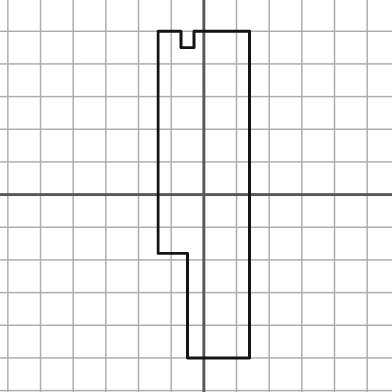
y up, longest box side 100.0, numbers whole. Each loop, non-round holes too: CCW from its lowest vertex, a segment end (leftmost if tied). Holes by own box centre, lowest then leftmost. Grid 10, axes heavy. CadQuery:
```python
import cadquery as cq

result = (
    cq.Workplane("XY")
    .moveTo(-5.0, -50.0)
    .lineTo(14.0, -50.0)
    .lineTo(14.0, 50.0)
    .lineTo(-3.0, 50.0)
    .lineTo(-3.0, 45.0)
    .lineTo(-7.0, 45.0)
    .lineTo(-7.0, 50.0)
    .lineTo(-14.0, 50.0)
    .lineTo(-14.0, -18.0)
    .lineTo(-5.0, -18.0)
    .close()
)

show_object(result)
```